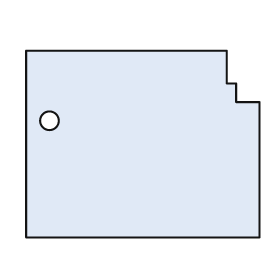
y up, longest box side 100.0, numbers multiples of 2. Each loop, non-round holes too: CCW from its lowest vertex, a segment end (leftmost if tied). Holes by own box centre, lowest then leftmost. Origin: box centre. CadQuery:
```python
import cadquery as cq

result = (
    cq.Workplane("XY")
    .moveTo(-50.0, -40.0)
    .lineTo(50.0, -40.0)
    .lineTo(50.0, 18.0)
    .lineTo(40.0, 18.0)
    .lineTo(40.0, 26.0)
    .lineTo(36.0, 26.0)
    .lineTo(36.0, 40.0)
    .lineTo(-50.0, 40.0)
    .close()
    .moveTo(-40.0, 10.0)
    .circle(4.0)
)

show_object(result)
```